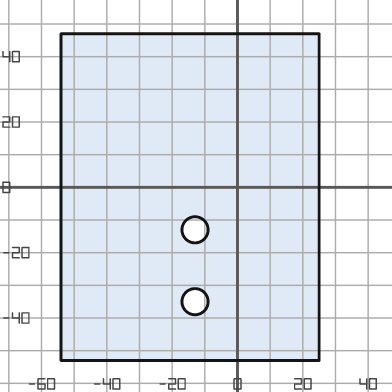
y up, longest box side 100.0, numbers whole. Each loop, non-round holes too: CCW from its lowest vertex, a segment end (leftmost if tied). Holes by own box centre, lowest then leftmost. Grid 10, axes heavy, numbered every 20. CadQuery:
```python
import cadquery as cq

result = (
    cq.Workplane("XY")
    .moveTo(-54.0, -53.0)
    .lineTo(25.0, -53.0)
    .lineTo(25.0, 47.0)
    .lineTo(-54.0, 47.0)
    .close()
    .moveTo(-13.0, -35.0)
    .circle(4.0)
    .moveTo(-13.0, -13.0)
    .circle(4.0)
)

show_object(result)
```